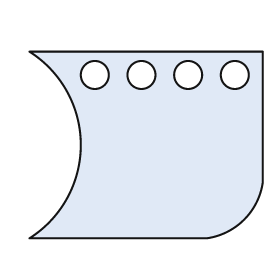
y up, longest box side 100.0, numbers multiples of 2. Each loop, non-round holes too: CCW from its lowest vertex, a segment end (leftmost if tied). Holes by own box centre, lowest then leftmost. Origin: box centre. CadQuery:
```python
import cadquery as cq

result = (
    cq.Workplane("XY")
    .moveTo(-50.0, -40.0)
    .lineTo(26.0, -40.0)
    .threePointArc((42.0, -32.0), (50.0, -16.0))
    .lineTo(50.0, 40.0)
    .lineTo(-50.0, 40.0)
    .threePointArc((-28.0, 0.0), (-50.0, -40.0))
    .close()
    .moveTo(-22.0, 30.0)
    .circle(6.0)
    .moveTo(-2.0, 30.0)
    .circle(6.0)
    .moveTo(18.0, 30.0)
    .circle(6.0)
    .moveTo(38.0, 30.0)
    .circle(6.0)
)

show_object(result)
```